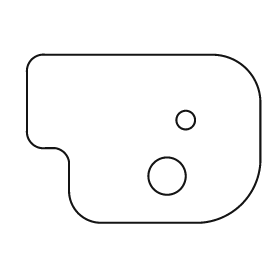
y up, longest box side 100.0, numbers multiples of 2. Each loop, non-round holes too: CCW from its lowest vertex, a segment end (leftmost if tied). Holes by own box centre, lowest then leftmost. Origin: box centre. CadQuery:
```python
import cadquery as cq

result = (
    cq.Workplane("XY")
    .moveTo(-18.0, -36.0)
    .lineTo(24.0, -36.0)
    .threePointArc((42.0, -28.0), (50.0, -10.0))
    .lineTo(50.0, 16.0)
    .threePointArc((44.0, 30.0), (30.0, 36.0))
    .lineTo(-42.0, 36.0)
    .threePointArc((-48.0, 34.0), (-50.0, 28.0))
    .lineTo(-50.0, 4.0)
    .threePointArc((-48.0, -2.0), (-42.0, -4.0))
    .lineTo(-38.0, -4.0)
    .threePointArc((-34.0, -6.0), (-32.0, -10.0))
    .lineTo(-32.0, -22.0)
    .threePointArc((-28.0, -32.0), (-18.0, -36.0))
    .close()
    .moveTo(10.0, -16.0)
    .circle(8.0)
    .moveTo(18.0, 8.0)
    .circle(4.0)
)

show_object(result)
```